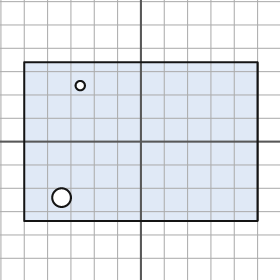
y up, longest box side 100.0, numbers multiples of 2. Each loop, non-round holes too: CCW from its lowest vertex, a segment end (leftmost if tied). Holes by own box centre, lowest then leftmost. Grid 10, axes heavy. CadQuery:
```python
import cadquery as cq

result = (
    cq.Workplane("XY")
    .moveTo(-50.0, -34.0)
    .lineTo(50.0, -34.0)
    .lineTo(50.0, 34.0)
    .lineTo(-50.0, 34.0)
    .close()
    .moveTo(-34.0, -24.0)
    .circle(4.0)
    .moveTo(-26.0, 24.0)
    .circle(2.0)
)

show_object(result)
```